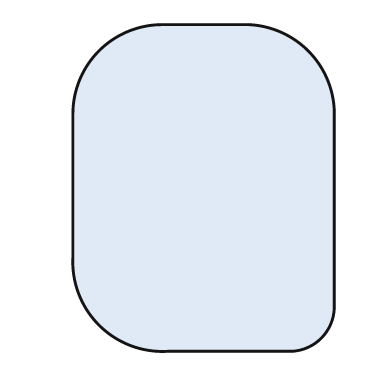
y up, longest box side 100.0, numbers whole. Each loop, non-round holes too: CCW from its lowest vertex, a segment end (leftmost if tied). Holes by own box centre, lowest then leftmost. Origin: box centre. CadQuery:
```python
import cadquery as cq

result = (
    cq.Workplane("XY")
    .moveTo(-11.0, -50.0)
    .lineTo(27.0, -50.0)
    .threePointArc((36.0, -46.0), (40.0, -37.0))
    .lineTo(40.0, 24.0)
    .threePointArc((32.0, 42.0), (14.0, 50.0))
    .lineTo(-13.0, 50.0)
    .threePointArc((-32.0, 42.0), (-40.0, 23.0))
    .lineTo(-40.0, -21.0)
    .threePointArc((-32.0, -42.0), (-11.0, -50.0))
    .close()
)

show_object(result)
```